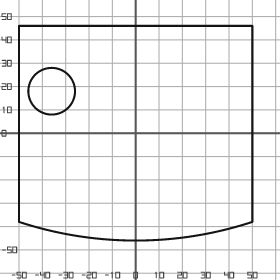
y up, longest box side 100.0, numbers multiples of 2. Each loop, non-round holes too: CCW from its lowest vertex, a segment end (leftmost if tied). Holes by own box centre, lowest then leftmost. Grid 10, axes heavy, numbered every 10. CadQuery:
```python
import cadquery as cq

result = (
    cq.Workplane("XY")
    .moveTo(-50.0, -38.0)
    .threePointArc((0.0, -46.0), (50.0, -38.0))
    .lineTo(50.0, 46.0)
    .lineTo(-50.0, 46.0)
    .close()
    .moveTo(-36.0, 18.0)
    .circle(10.0)
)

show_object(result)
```